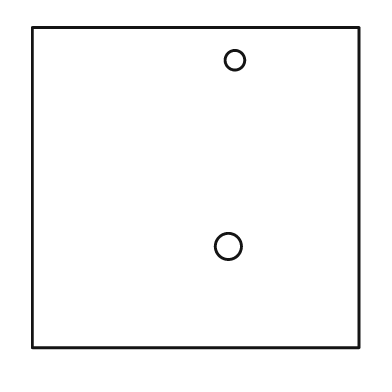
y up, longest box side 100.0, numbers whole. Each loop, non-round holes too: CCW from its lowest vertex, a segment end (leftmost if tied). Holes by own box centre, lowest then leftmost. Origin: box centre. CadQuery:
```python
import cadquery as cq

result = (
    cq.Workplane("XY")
    .moveTo(-50.0, -49.0)
    .lineTo(50.0, -49.0)
    .lineTo(50.0, 49.0)
    .lineTo(-50.0, 49.0)
    .close()
    .moveTo(10.0, -18.0)
    .circle(4.0)
    .moveTo(12.0, 39.0)
    .circle(3.0)
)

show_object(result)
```